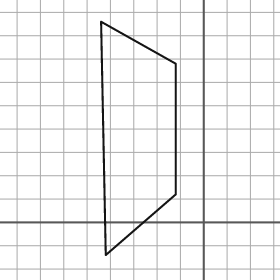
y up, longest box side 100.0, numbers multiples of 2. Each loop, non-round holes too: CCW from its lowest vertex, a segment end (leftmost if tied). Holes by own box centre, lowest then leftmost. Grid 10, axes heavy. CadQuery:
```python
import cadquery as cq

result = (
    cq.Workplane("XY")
    .moveTo(-42.0, -14.0)
    .lineTo(-12.0, 12.0)
    .lineTo(-12.0, 68.0)
    .lineTo(-44.0, 86.0)
    .close()
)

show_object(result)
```